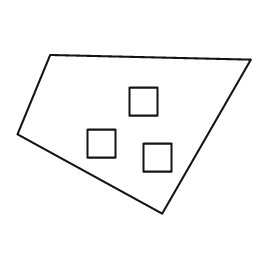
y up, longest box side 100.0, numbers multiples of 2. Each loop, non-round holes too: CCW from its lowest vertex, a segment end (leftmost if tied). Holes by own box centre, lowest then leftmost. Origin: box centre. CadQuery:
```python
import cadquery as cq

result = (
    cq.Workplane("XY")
    .moveTo(12.0, -34.0)
    .lineTo(50.0, 32.0)
    .lineTo(-36.0, 34.0)
    .lineTo(-50.0, 0.0)
    .close()
    .moveTo(4.0, -16.0)
    .lineTo(16.0, -16.0)
    .lineTo(16.0, -4.0)
    .lineTo(4.0, -4.0)
    .close()
    .moveTo(-20.0, -10.0)
    .lineTo(-8.0, -10.0)
    .lineTo(-8.0, 2.0)
    .lineTo(-20.0, 2.0)
    .close()
    .moveTo(-2.0, 8.0)
    .lineTo(10.0, 8.0)
    .lineTo(10.0, 20.0)
    .lineTo(-2.0, 20.0)
    .close()
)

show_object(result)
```